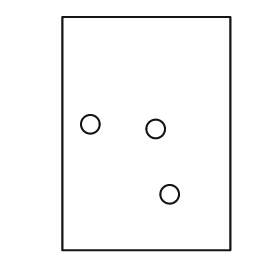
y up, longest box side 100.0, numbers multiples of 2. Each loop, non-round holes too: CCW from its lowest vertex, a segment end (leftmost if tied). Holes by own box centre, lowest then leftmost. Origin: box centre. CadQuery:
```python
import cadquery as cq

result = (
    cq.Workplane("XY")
    .moveTo(-36.0, -50.0)
    .lineTo(36.0, -50.0)
    .lineTo(36.0, 50.0)
    .lineTo(-36.0, 50.0)
    .close()
    .moveTo(10.0, -26.0)
    .circle(4.0)
    .moveTo(4.0, 2.0)
    .circle(4.0)
    .moveTo(-24.0, 4.0)
    .circle(4.0)
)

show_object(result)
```